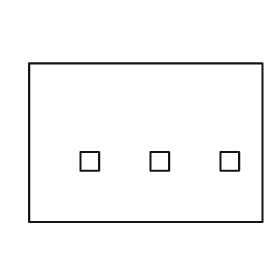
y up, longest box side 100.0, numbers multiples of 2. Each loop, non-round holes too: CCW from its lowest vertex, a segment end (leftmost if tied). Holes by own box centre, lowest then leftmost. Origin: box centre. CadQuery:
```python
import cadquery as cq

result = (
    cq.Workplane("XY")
    .moveTo(-50.0, -34.0)
    .lineTo(50.0, -34.0)
    .lineTo(50.0, 34.0)
    .lineTo(-50.0, 34.0)
    .close()
    .moveTo(-28.0, -12.0)
    .lineTo(-20.0, -12.0)
    .lineTo(-20.0, -4.0)
    .lineTo(-28.0, -4.0)
    .close()
    .moveTo(2.0, -12.0)
    .lineTo(10.0, -12.0)
    .lineTo(10.0, -4.0)
    .lineTo(2.0, -4.0)
    .close()
    .moveTo(32.0, -12.0)
    .lineTo(40.0, -12.0)
    .lineTo(40.0, -4.0)
    .lineTo(32.0, -4.0)
    .close()
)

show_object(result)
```